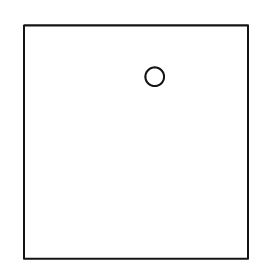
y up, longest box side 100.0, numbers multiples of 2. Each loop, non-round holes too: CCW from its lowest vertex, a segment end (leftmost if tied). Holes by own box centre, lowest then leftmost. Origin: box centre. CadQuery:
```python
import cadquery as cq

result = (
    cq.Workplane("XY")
    .moveTo(-48.0, -50.0)
    .lineTo(48.0, -50.0)
    .lineTo(48.0, 50.0)
    .lineTo(-48.0, 50.0)
    .close()
    .moveTo(8.0, 28.0)
    .circle(4.0)
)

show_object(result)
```